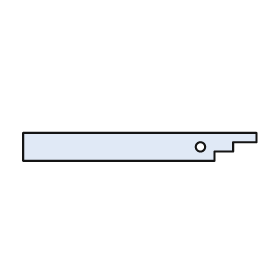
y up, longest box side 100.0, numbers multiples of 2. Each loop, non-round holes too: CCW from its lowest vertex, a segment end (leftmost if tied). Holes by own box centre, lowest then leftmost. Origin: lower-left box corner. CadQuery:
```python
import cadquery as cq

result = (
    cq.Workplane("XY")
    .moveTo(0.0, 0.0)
    .lineTo(82.0, 0.0)
    .lineTo(82.0, 4.0)
    .lineTo(90.0, 4.0)
    .lineTo(90.0, 8.0)
    .lineTo(100.0, 8.0)
    .lineTo(100.0, 12.0)
    .lineTo(0.0, 12.0)
    .close()
    .moveTo(76.0, 6.0)
    .circle(2.0)
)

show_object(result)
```